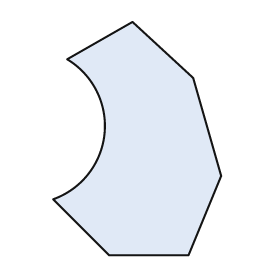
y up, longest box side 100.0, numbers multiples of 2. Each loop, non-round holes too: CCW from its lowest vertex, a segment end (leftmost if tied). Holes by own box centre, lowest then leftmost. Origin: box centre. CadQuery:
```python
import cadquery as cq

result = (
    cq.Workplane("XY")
    .moveTo(-12.0, -50.0)
    .lineTo(22.0, -50.0)
    .lineTo(36.0, -16.0)
    .lineTo(24.0, 26.0)
    .lineTo(-2.0, 50.0)
    .lineTo(-30.0, 34.0)
    .threePointArc((-14.0, 2.0), (-36.0, -26.0))
    .close()
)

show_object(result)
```